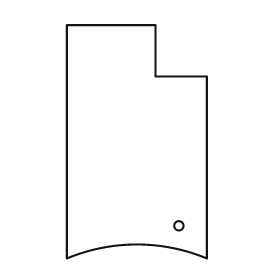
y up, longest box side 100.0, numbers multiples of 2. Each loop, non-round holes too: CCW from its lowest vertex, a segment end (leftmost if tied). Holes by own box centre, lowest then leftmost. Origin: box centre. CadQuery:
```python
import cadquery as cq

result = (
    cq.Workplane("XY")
    .moveTo(-30.0, -50.0)
    .threePointArc((0.0, -44.0), (30.0, -50.0))
    .lineTo(30.0, 28.0)
    .lineTo(8.0, 28.0)
    .lineTo(8.0, 50.0)
    .lineTo(-30.0, 50.0)
    .close()
    .moveTo(18.0, -36.0)
    .circle(2.0)
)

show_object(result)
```